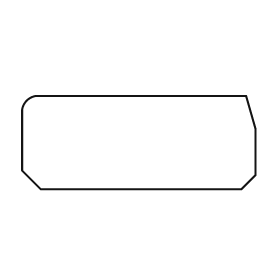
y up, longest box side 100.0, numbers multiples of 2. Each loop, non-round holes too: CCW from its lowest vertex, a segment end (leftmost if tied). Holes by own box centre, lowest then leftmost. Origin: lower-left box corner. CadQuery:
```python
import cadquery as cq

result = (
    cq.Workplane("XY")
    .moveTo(8.0, 0.0)
    .lineTo(94.0, 0.0)
    .lineTo(100.0, 6.0)
    .lineTo(100.0, 26.0)
    .lineTo(96.0, 40.0)
    .lineTo(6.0, 40.0)
    .threePointArc((2.0, 38.0), (0.0, 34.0))
    .lineTo(0.0, 8.0)
    .close()
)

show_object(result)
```